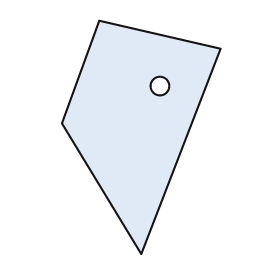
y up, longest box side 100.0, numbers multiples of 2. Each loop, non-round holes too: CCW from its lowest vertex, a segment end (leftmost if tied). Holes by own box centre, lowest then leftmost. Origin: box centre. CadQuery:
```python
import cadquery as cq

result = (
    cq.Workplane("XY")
    .moveTo(0.0, -50.0)
    .lineTo(34.0, 38.0)
    .lineTo(-18.0, 50.0)
    .lineTo(-34.0, 6.0)
    .close()
    .moveTo(8.0, 22.0)
    .circle(4.0)
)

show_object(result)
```